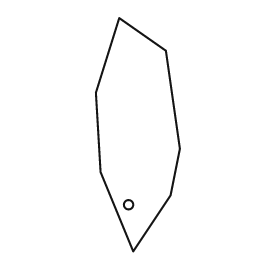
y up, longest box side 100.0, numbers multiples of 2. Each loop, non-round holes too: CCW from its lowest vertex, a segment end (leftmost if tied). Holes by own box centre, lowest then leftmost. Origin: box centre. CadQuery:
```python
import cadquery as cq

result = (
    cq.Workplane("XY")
    .moveTo(-2.0, -50.0)
    .lineTo(14.0, -26.0)
    .lineTo(18.0, -6.0)
    .lineTo(12.0, 36.0)
    .lineTo(-8.0, 50.0)
    .lineTo(-18.0, 18.0)
    .lineTo(-16.0, -16.0)
    .close()
    .moveTo(-4.0, -30.0)
    .circle(2.0)
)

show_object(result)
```